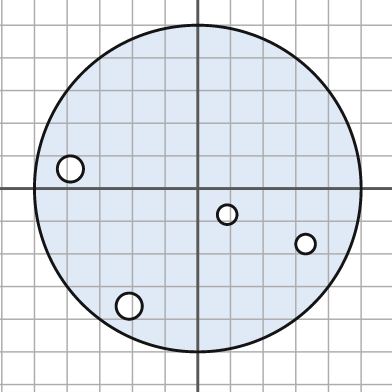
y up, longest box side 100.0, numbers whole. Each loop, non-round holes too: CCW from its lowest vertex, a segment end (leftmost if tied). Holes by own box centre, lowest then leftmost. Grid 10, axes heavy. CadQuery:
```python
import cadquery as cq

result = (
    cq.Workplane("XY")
    .moveTo(0.0, 0.0)
    .circle(50.0)
    .moveTo(-21.0, -36.0)
    .circle(4.0)
    .moveTo(33.0, -17.0)
    .circle(3.0)
    .moveTo(9.0, -8.0)
    .circle(3.0)
    .moveTo(-39.0, 6.0)
    .circle(4.0)
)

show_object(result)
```